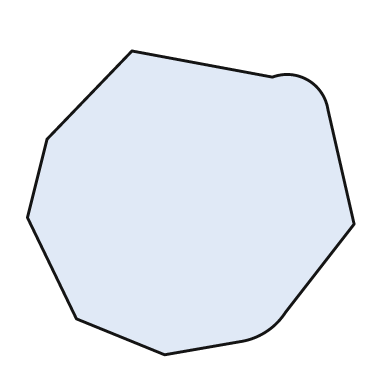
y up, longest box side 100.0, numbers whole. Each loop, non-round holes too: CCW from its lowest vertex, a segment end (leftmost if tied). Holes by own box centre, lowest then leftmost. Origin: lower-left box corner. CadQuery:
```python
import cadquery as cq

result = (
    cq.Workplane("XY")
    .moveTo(42.0, 0.0)
    .lineTo(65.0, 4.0)
    .threePointArc((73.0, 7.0), (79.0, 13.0))
    .lineTo(100.0, 40.0)
    .lineTo(92.0, 75.0)
    .threePointArc((86.0, 84.0), (75.0, 85.0))
    .lineTo(32.0, 93.0)
    .lineTo(6.0, 66.0)
    .lineTo(0.0, 42.0)
    .lineTo(15.0, 11.0)
    .close()
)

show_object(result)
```